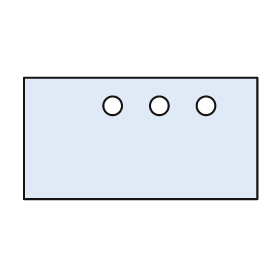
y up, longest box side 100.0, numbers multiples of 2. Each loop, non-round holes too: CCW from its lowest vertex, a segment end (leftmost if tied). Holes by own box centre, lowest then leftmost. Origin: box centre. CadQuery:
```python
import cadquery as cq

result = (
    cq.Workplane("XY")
    .moveTo(-50.0, -26.0)
    .lineTo(50.0, -26.0)
    .lineTo(50.0, 26.0)
    .lineTo(-50.0, 26.0)
    .close()
    .moveTo(-12.0, 14.0)
    .circle(4.0)
    .moveTo(8.0, 14.0)
    .circle(4.0)
    .moveTo(28.0, 14.0)
    .circle(4.0)
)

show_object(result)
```